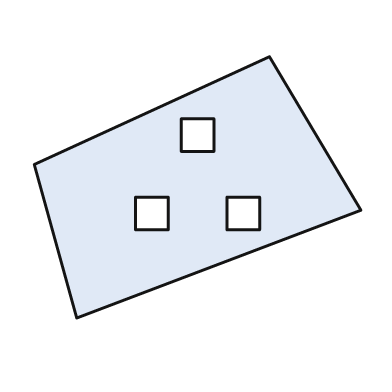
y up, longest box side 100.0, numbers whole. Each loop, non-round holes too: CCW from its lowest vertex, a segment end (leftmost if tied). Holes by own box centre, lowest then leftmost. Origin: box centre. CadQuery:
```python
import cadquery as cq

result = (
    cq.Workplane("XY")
    .moveTo(-37.0, -40.0)
    .lineTo(50.0, -7.0)
    .lineTo(22.0, 40.0)
    .lineTo(-50.0, 7.0)
    .close()
    .moveTo(-19.0, -13.0)
    .lineTo(-9.0, -13.0)
    .lineTo(-9.0, -3.0)
    .lineTo(-19.0, -3.0)
    .close()
    .moveTo(9.0, -13.0)
    .lineTo(19.0, -13.0)
    .lineTo(19.0, -3.0)
    .lineTo(9.0, -3.0)
    .close()
    .moveTo(-5.0, 11.0)
    .lineTo(5.0, 11.0)
    .lineTo(5.0, 21.0)
    .lineTo(-5.0, 21.0)
    .close()
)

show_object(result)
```